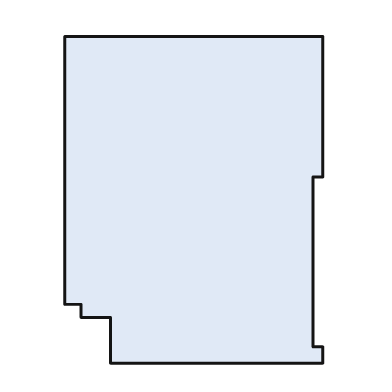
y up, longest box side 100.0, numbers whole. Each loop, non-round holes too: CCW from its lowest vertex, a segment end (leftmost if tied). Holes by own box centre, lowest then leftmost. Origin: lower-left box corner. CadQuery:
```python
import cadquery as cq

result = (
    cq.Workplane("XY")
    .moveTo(14.0, 0.0)
    .lineTo(79.0, 0.0)
    .lineTo(79.0, 5.0)
    .lineTo(76.0, 5.0)
    .lineTo(76.0, 57.0)
    .lineTo(79.0, 57.0)
    .lineTo(79.0, 100.0)
    .lineTo(0.0, 100.0)
    .lineTo(0.0, 18.0)
    .lineTo(5.0, 18.0)
    .lineTo(5.0, 14.0)
    .lineTo(14.0, 14.0)
    .close()
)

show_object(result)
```